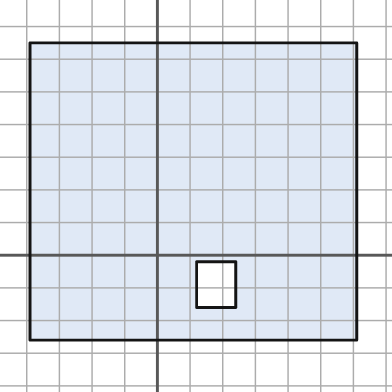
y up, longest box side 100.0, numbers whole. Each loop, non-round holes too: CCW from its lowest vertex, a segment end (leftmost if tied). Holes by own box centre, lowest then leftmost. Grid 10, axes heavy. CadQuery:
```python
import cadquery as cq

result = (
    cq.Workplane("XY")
    .moveTo(-39.0, -26.0)
    .lineTo(61.0, -26.0)
    .lineTo(61.0, 65.0)
    .lineTo(-39.0, 65.0)
    .close()
    .moveTo(12.0, -16.0)
    .lineTo(24.0, -16.0)
    .lineTo(24.0, -2.0)
    .lineTo(12.0, -2.0)
    .close()
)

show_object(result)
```